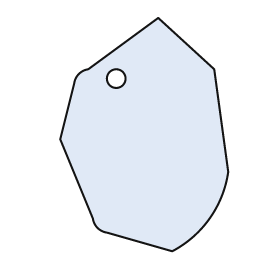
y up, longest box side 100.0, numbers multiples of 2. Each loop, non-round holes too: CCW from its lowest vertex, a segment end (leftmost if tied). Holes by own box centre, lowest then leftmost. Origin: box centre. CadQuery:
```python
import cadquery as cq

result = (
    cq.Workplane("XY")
    .moveTo(12.0, -50.0)
    .threePointArc((28.0, -36.0), (36.0, -16.0))
    .lineTo(30.0, 28.0)
    .lineTo(6.0, 50.0)
    .lineTo(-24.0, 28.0)
    .threePointArc((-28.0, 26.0), (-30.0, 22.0))
    .lineTo(-36.0, -2.0)
    .lineTo(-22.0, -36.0)
    .threePointArc((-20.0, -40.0), (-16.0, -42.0))
    .close()
    .moveTo(-12.0, 24.0)
    .circle(4.0)
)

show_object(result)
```